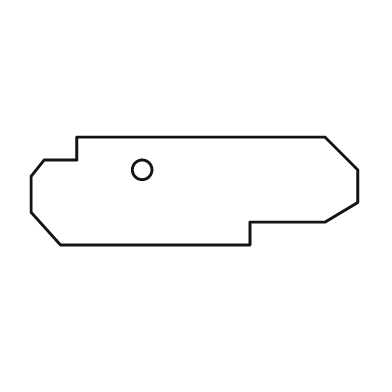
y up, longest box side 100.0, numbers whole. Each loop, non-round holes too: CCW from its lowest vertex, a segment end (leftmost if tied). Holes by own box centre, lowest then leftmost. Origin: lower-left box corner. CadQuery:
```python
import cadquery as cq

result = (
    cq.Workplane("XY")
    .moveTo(9.0, 0.0)
    .lineTo(67.0, 0.0)
    .lineTo(67.0, 7.0)
    .lineTo(90.0, 7.0)
    .lineTo(100.0, 13.0)
    .lineTo(100.0, 23.0)
    .lineTo(90.0, 33.0)
    .lineTo(14.0, 33.0)
    .lineTo(14.0, 26.0)
    .lineTo(4.0, 26.0)
    .lineTo(0.0, 21.0)
    .lineTo(0.0, 10.0)
    .close()
    .moveTo(34.0, 23.0)
    .circle(3.0)
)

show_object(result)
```